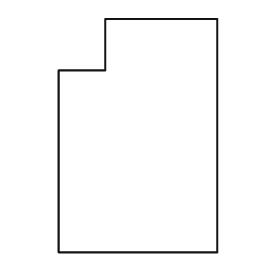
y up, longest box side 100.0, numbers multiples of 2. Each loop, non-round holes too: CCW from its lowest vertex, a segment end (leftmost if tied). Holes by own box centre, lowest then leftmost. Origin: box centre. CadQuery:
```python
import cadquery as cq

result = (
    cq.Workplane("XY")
    .moveTo(-34.0, -50.0)
    .lineTo(34.0, -50.0)
    .lineTo(34.0, 50.0)
    .lineTo(-14.0, 50.0)
    .lineTo(-14.0, 28.0)
    .lineTo(-34.0, 28.0)
    .close()
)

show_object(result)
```